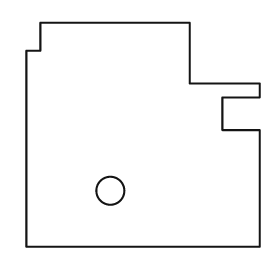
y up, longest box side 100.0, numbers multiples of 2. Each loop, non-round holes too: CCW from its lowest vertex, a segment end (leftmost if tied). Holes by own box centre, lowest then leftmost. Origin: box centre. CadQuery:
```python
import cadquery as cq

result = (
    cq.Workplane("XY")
    .moveTo(-50.0, -48.0)
    .lineTo(50.0, -48.0)
    .lineTo(50.0, 2.0)
    .lineTo(34.0, 2.0)
    .lineTo(34.0, 16.0)
    .lineTo(50.0, 16.0)
    .lineTo(50.0, 22.0)
    .lineTo(20.0, 22.0)
    .lineTo(20.0, 48.0)
    .lineTo(-44.0, 48.0)
    .lineTo(-44.0, 36.0)
    .lineTo(-50.0, 36.0)
    .close()
    .moveTo(-14.0, -24.0)
    .circle(6.0)
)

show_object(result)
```